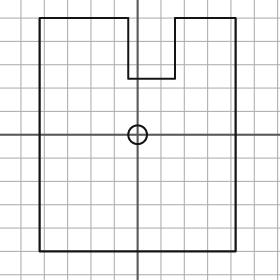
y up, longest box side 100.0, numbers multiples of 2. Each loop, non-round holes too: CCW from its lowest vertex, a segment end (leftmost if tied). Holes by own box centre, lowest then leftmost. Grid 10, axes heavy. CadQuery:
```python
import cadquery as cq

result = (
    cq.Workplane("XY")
    .moveTo(-42.0, -50.0)
    .lineTo(42.0, -50.0)
    .lineTo(42.0, 50.0)
    .lineTo(16.0, 50.0)
    .lineTo(16.0, 24.0)
    .lineTo(-4.0, 24.0)
    .lineTo(-4.0, 50.0)
    .lineTo(-42.0, 50.0)
    .close()
    .moveTo(0.0, 0.0)
    .circle(4.0)
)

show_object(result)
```